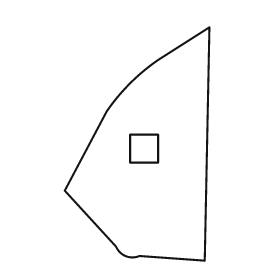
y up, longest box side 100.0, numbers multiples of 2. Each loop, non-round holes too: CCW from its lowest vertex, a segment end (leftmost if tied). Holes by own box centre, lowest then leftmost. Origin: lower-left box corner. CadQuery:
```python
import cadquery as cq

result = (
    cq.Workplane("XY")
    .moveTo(60.0, 0.0)
    .lineTo(62.0, 100.0)
    .lineTo(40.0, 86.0)
    .threePointArc((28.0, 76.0), (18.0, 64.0))
    .lineTo(0.0, 30.0)
    .lineTo(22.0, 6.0)
    .threePointArc((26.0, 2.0), (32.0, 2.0))
    .close()
    .moveTo(28.0, 42.0)
    .lineTo(40.0, 42.0)
    .lineTo(40.0, 54.0)
    .lineTo(28.0, 54.0)
    .close()
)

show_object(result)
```